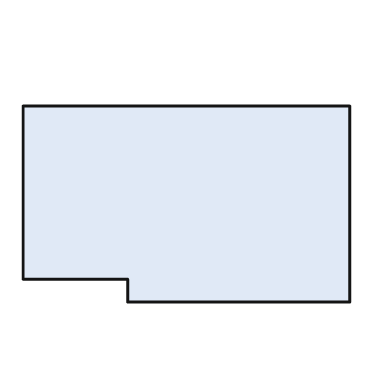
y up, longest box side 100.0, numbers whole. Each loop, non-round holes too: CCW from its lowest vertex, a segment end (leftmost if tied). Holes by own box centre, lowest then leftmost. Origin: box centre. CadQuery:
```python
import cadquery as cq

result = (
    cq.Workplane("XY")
    .moveTo(-18.0, -30.0)
    .lineTo(50.0, -30.0)
    .lineTo(50.0, 30.0)
    .lineTo(-50.0, 30.0)
    .lineTo(-50.0, -23.0)
    .lineTo(-18.0, -23.0)
    .close()
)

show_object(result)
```